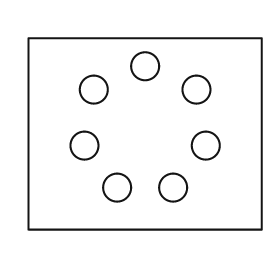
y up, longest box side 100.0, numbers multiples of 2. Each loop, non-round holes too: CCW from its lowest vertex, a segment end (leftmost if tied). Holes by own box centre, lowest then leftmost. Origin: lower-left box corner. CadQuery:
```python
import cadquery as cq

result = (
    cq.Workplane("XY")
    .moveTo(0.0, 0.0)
    .lineTo(100.0, 0.0)
    .lineTo(100.0, 82.0)
    .lineTo(0.0, 82.0)
    .close()
    .moveTo(38.0, 18.0)
    .circle(6.0)
    .moveTo(62.0, 18.0)
    .circle(6.0)
    .moveTo(24.0, 36.0)
    .circle(6.0)
    .moveTo(76.0, 36.0)
    .circle(6.0)
    .moveTo(28.0, 60.0)
    .circle(6.0)
    .moveTo(72.0, 60.0)
    .circle(6.0)
    .moveTo(50.0, 70.0)
    .circle(6.0)
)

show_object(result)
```